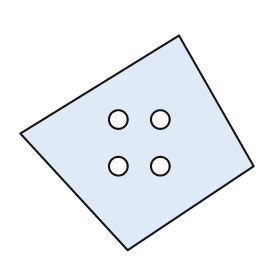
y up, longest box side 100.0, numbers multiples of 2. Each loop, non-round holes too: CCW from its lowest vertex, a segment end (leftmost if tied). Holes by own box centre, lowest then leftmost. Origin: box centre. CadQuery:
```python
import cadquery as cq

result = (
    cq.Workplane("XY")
    .moveTo(-4.0, -46.0)
    .lineTo(50.0, -10.0)
    .lineTo(18.0, 46.0)
    .lineTo(-50.0, 4.0)
    .close()
    .moveTo(-8.0, -10.0)
    .circle(4.0)
    .moveTo(10.0, -10.0)
    .circle(4.0)
    .moveTo(-8.0, 10.0)
    .circle(4.0)
    .moveTo(10.0, 10.0)
    .circle(4.0)
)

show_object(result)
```